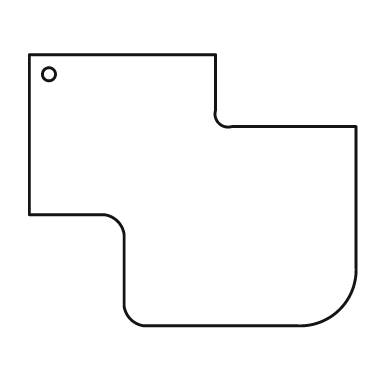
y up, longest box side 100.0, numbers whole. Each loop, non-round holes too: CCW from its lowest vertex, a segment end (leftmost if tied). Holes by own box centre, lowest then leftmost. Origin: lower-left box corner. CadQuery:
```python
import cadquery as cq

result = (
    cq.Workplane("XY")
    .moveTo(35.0, 0.0)
    .lineTo(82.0, 0.0)
    .threePointArc((95.0, 5.0), (100.0, 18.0))
    .lineTo(100.0, 61.0)
    .lineTo(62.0, 61.0)
    .threePointArc((58.0, 62.0), (57.0, 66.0))
    .lineTo(57.0, 83.0)
    .lineTo(0.0, 83.0)
    .lineTo(0.0, 34.0)
    .lineTo(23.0, 34.0)
    .threePointArc((27.0, 32.0), (29.0, 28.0))
    .lineTo(29.0, 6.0)
    .threePointArc((31.0, 2.0), (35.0, 0.0))
    .close()
    .moveTo(6.0, 77.0)
    .circle(2.0)
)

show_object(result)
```